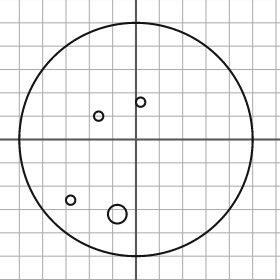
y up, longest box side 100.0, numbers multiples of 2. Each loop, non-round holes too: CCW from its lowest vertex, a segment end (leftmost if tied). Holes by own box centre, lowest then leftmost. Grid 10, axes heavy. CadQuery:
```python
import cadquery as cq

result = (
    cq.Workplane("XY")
    .moveTo(0.0, 0.0)
    .circle(50.0)
    .moveTo(-8.0, -32.0)
    .circle(4.0)
    .moveTo(-28.0, -26.0)
    .circle(2.0)
    .moveTo(-16.0, 10.0)
    .circle(2.0)
    .moveTo(2.0, 16.0)
    .circle(2.0)
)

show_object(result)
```